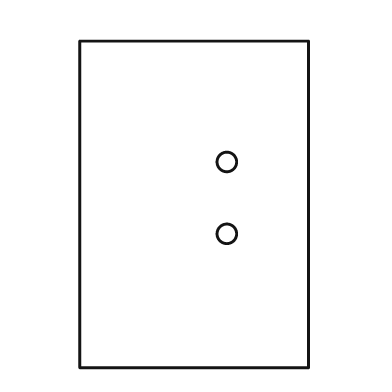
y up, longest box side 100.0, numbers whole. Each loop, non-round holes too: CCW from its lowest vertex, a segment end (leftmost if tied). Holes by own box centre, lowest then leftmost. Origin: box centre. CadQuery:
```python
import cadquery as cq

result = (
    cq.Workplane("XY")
    .moveTo(-35.0, -50.0)
    .lineTo(35.0, -50.0)
    .lineTo(35.0, 50.0)
    .lineTo(-35.0, 50.0)
    .close()
    .moveTo(10.0, -9.0)
    .circle(3.0)
    .moveTo(10.0, 13.0)
    .circle(3.0)
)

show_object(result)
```